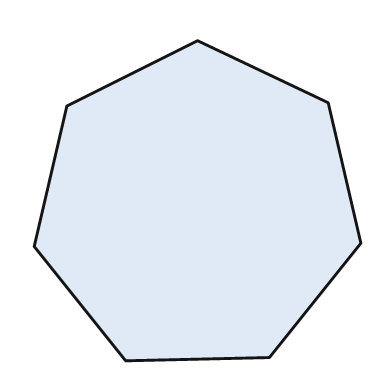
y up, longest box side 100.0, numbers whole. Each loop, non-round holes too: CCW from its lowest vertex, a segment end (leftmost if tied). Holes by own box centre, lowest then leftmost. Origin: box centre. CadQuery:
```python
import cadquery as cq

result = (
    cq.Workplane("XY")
    .moveTo(-22.0, -49.0)
    .lineTo(22.0, -48.0)
    .lineTo(50.0, -13.0)
    .lineTo(40.0, 30.0)
    .lineTo(0.0, 49.0)
    .lineTo(-40.0, 29.0)
    .lineTo(-50.0, -14.0)
    .close()
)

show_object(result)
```